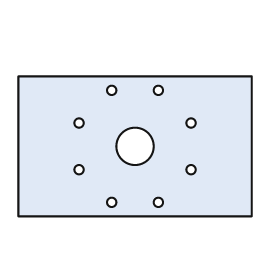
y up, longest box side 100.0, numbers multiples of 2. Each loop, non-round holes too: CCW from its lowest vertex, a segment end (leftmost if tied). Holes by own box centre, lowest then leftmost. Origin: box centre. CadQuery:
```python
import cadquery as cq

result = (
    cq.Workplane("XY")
    .moveTo(-50.0, -30.0)
    .lineTo(50.0, -30.0)
    .lineTo(50.0, 30.0)
    .lineTo(-50.0, 30.0)
    .close()
    .moveTo(-10.0, -24.0)
    .circle(2.0)
    .moveTo(10.0, -24.0)
    .circle(2.0)
    .moveTo(-24.0, -10.0)
    .circle(2.0)
    .moveTo(24.0, -10.0)
    .circle(2.0)
    .moveTo(0.0, 0.0)
    .circle(8.0)
    .moveTo(-24.0, 10.0)
    .circle(2.0)
    .moveTo(24.0, 10.0)
    .circle(2.0)
    .moveTo(-10.0, 24.0)
    .circle(2.0)
    .moveTo(10.0, 24.0)
    .circle(2.0)
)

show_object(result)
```